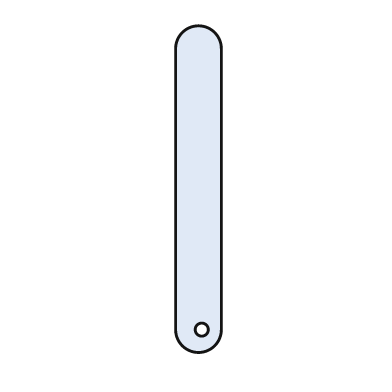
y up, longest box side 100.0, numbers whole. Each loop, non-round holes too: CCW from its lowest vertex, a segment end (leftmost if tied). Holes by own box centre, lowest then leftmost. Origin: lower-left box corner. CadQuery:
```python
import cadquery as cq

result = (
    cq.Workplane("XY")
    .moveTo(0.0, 7.0)
    .threePointArc((7.0, 0.0), (14.0, 7.0))
    .lineTo(14.0, 93.0)
    .threePointArc((7.0, 100.0), (0.0, 93.0))
    .close()
    .moveTo(8.0, 7.0)
    .circle(2.0)
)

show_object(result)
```